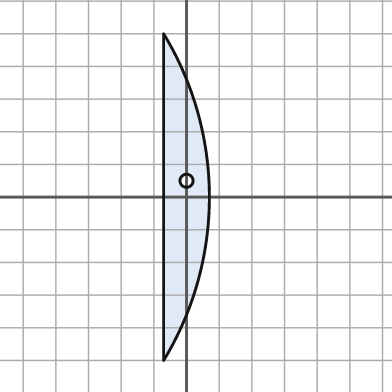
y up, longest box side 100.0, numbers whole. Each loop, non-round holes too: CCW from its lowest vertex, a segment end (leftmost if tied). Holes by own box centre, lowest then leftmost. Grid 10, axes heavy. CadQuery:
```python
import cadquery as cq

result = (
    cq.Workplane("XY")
    .moveTo(-7.0, -50.0)
    .threePointArc((7.0, 0.0), (-7.0, 50.0))
    .close()
    .moveTo(0.0, 5.0)
    .circle(2.0)
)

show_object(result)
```